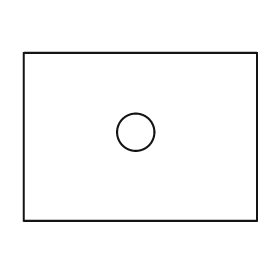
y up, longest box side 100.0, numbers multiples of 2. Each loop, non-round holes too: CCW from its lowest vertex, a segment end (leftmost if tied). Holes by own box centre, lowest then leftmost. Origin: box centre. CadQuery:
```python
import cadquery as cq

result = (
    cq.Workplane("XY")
    .moveTo(-50.0, -36.0)
    .lineTo(50.0, -36.0)
    .lineTo(50.0, 36.0)
    .lineTo(-50.0, 36.0)
    .close()
    .moveTo(-2.0, 2.0)
    .circle(8.0)
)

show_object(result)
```